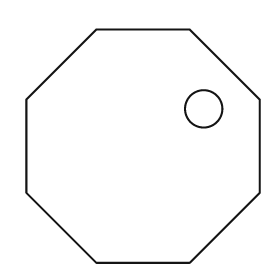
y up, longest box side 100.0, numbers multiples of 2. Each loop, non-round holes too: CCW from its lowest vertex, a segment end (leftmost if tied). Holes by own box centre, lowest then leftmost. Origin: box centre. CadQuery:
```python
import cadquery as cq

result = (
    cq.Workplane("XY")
    .moveTo(-20.0, -50.0)
    .lineTo(20.0, -50.0)
    .lineTo(50.0, -20.0)
    .lineTo(50.0, 20.0)
    .lineTo(20.0, 50.0)
    .lineTo(-20.0, 50.0)
    .lineTo(-50.0, 20.0)
    .lineTo(-50.0, -20.0)
    .close()
    .moveTo(26.0, 16.0)
    .circle(8.0)
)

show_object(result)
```